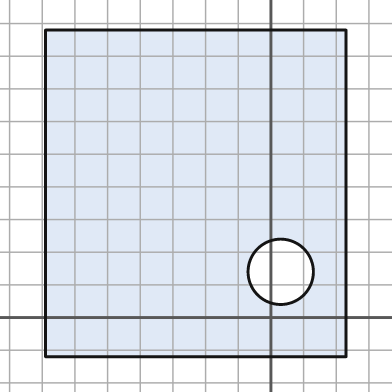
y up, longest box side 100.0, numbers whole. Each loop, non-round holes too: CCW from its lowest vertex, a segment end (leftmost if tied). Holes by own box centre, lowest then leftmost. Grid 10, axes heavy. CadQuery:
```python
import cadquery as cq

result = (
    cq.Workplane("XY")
    .moveTo(-69.0, -12.0)
    .lineTo(23.0, -12.0)
    .lineTo(23.0, 88.0)
    .lineTo(-69.0, 88.0)
    .close()
    .moveTo(3.0, 14.0)
    .circle(10.0)
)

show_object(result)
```